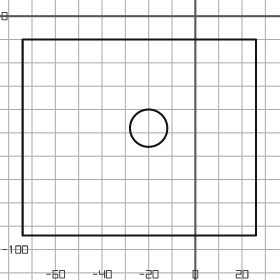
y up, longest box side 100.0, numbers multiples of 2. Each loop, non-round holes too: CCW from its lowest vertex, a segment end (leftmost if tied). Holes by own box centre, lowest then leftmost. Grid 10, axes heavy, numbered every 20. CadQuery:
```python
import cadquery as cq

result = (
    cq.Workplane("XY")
    .moveTo(-74.0, -94.0)
    .lineTo(26.0, -94.0)
    .lineTo(26.0, -10.0)
    .lineTo(-74.0, -10.0)
    .close()
    .moveTo(-20.0, -48.0)
    .circle(8.0)
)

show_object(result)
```